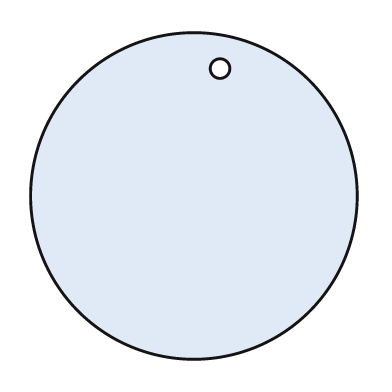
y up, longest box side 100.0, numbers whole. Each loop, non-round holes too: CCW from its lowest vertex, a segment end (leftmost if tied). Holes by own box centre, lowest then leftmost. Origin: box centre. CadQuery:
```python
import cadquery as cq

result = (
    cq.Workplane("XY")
    .moveTo(0.0, 0.0)
    .circle(50.0)
    .moveTo(8.0, 39.0)
    .circle(3.0)
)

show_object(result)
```